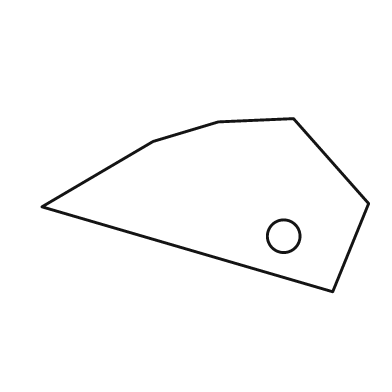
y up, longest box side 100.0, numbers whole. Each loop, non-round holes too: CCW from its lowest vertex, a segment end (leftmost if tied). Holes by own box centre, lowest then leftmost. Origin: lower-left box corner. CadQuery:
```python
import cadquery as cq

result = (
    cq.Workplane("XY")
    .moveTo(89.0, 0.0)
    .lineTo(100.0, 27.0)
    .lineTo(77.0, 53.0)
    .lineTo(54.0, 52.0)
    .lineTo(34.0, 46.0)
    .lineTo(0.0, 26.0)
    .close()
    .moveTo(74.0, 17.0)
    .circle(5.0)
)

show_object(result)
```